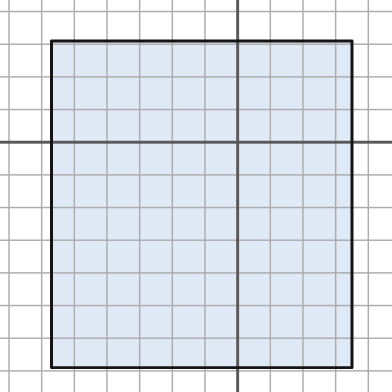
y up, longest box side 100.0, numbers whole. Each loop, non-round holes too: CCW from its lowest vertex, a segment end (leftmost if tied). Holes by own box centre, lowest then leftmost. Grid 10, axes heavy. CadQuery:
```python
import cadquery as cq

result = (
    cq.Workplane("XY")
    .moveTo(-57.0, -69.0)
    .lineTo(35.0, -69.0)
    .lineTo(35.0, 31.0)
    .lineTo(-57.0, 31.0)
    .close()
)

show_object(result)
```